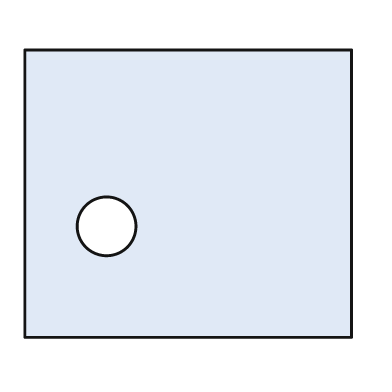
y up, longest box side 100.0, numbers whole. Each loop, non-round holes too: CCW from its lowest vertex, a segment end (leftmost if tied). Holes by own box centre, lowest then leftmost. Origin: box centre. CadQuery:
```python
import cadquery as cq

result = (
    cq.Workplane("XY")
    .moveTo(-50.0, -44.0)
    .lineTo(50.0, -44.0)
    .lineTo(50.0, 44.0)
    .lineTo(-50.0, 44.0)
    .close()
    .moveTo(-25.0, -10.0)
    .circle(9.0)
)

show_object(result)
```